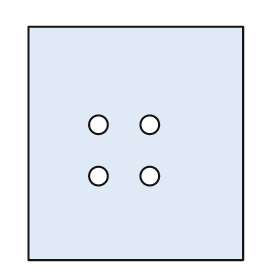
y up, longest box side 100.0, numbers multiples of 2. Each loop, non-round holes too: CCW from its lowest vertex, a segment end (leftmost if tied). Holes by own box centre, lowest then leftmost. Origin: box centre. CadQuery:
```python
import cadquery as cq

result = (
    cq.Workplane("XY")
    .moveTo(-46.0, -50.0)
    .lineTo(46.0, -50.0)
    .lineTo(46.0, 50.0)
    .lineTo(-46.0, 50.0)
    .close()
    .moveTo(-16.0, -14.0)
    .circle(4.0)
    .moveTo(6.0, -14.0)
    .circle(4.0)
    .moveTo(-16.0, 8.0)
    .circle(4.0)
    .moveTo(6.0, 8.0)
    .circle(4.0)
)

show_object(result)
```